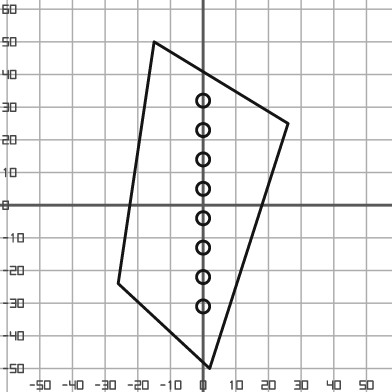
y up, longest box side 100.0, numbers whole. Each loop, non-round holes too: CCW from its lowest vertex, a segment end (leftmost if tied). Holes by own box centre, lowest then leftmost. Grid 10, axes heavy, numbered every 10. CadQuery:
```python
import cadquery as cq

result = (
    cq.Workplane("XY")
    .moveTo(2.0, -50.0)
    .lineTo(26.0, 25.0)
    .lineTo(-15.0, 50.0)
    .lineTo(-26.0, -24.0)
    .close()
    .moveTo(0.0, -31.0)
    .circle(2.0)
    .moveTo(0.0, -22.0)
    .circle(2.0)
    .moveTo(0.0, -13.0)
    .circle(2.0)
    .moveTo(0.0, -4.0)
    .circle(2.0)
    .moveTo(0.0, 5.0)
    .circle(2.0)
    .moveTo(0.0, 14.0)
    .circle(2.0)
    .moveTo(0.0, 23.0)
    .circle(2.0)
    .moveTo(0.0, 32.0)
    .circle(2.0)
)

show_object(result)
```